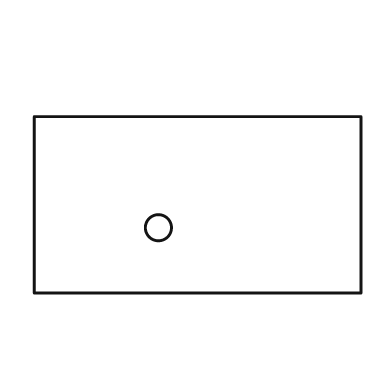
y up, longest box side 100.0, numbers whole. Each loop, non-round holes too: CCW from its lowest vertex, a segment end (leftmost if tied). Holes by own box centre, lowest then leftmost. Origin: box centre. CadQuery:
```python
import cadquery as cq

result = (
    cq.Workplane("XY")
    .moveTo(-50.0, -27.0)
    .lineTo(50.0, -27.0)
    .lineTo(50.0, 27.0)
    .lineTo(-50.0, 27.0)
    .close()
    .moveTo(-12.0, -7.0)
    .circle(4.0)
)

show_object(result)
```